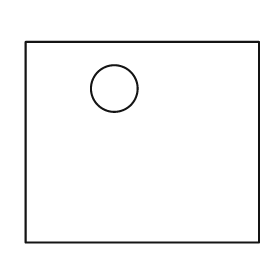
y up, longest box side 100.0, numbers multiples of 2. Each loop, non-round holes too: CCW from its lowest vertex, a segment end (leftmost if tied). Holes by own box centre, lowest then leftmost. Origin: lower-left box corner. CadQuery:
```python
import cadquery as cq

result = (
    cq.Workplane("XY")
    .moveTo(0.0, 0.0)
    .lineTo(100.0, 0.0)
    .lineTo(100.0, 86.0)
    .lineTo(0.0, 86.0)
    .close()
    .moveTo(38.0, 66.0)
    .circle(10.0)
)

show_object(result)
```